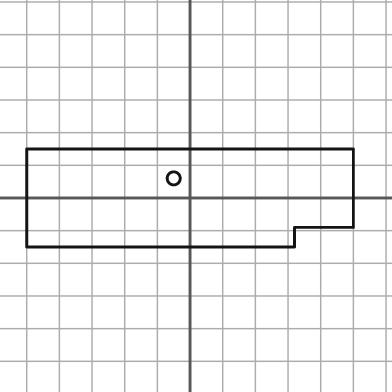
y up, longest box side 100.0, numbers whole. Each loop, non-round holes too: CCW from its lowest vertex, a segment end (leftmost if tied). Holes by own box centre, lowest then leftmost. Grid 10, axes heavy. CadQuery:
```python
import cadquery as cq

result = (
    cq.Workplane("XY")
    .moveTo(-50.0, -15.0)
    .lineTo(32.0, -15.0)
    .lineTo(32.0, -9.0)
    .lineTo(50.0, -9.0)
    .lineTo(50.0, 15.0)
    .lineTo(-50.0, 15.0)
    .close()
    .moveTo(-5.0, 6.0)
    .circle(2.0)
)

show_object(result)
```